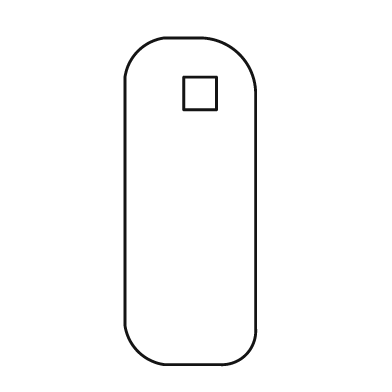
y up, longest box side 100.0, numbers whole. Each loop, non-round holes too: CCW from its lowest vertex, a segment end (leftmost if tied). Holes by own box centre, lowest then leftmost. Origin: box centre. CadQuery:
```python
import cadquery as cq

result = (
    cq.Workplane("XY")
    .moveTo(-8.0, -50.0)
    .lineTo(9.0, -50.0)
    .threePointArc((17.0, -47.0), (20.0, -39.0))
    .lineTo(20.0, 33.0)
    .threePointArc((15.0, 45.0), (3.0, 50.0))
    .lineTo(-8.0, 50.0)
    .threePointArc((-16.0, 46.0), (-20.0, 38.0))
    .lineTo(-20.0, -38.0)
    .threePointArc((-16.0, -46.0), (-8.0, -50.0))
    .close()
    .moveTo(-2.0, 28.0)
    .lineTo(8.0, 28.0)
    .lineTo(8.0, 38.0)
    .lineTo(-2.0, 38.0)
    .close()
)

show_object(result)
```